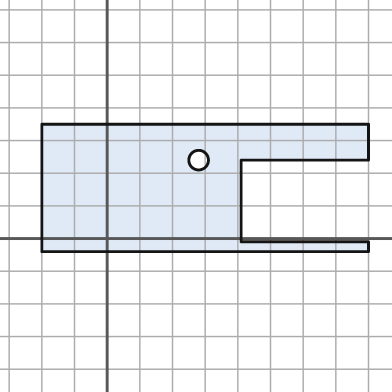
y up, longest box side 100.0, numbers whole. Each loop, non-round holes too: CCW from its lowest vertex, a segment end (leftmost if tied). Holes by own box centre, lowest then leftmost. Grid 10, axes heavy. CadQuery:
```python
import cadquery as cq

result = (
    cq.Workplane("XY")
    .moveTo(-20.0, -4.0)
    .lineTo(80.0, -4.0)
    .lineTo(80.0, -1.0)
    .lineTo(41.0, -1.0)
    .lineTo(41.0, 24.0)
    .lineTo(80.0, 24.0)
    .lineTo(80.0, 35.0)
    .lineTo(-20.0, 35.0)
    .close()
    .moveTo(28.0, 24.0)
    .circle(3.0)
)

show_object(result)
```